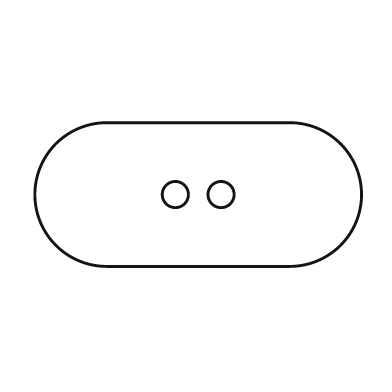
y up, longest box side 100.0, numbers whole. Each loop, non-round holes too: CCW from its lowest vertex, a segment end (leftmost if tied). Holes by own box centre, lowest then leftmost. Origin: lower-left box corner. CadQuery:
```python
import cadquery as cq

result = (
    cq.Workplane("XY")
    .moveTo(22.0, 0.0)
    .lineTo(78.0, 0.0)
    .threePointArc((100.0, 22.0), (78.0, 44.0))
    .lineTo(22.0, 44.0)
    .threePointArc((0.0, 22.0), (22.0, 0.0))
    .close()
    .moveTo(43.0, 22.0)
    .circle(4.0)
    .moveTo(57.0, 22.0)
    .circle(4.0)
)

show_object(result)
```